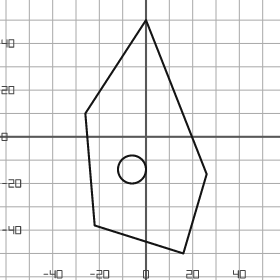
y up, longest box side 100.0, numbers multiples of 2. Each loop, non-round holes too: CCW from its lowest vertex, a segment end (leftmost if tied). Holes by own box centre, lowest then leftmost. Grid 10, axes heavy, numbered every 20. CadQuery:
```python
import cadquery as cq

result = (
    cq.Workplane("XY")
    .moveTo(16.0, -50.0)
    .lineTo(26.0, -16.0)
    .lineTo(0.0, 50.0)
    .lineTo(-26.0, 10.0)
    .lineTo(-22.0, -38.0)
    .close()
    .moveTo(-6.0, -14.0)
    .circle(6.0)
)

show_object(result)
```